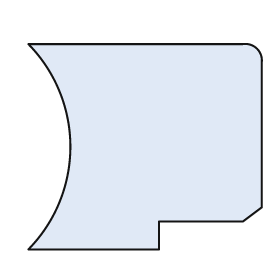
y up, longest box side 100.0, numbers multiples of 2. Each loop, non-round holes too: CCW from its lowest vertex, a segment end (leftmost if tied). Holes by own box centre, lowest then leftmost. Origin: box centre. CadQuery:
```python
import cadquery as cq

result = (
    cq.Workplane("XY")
    .moveTo(-50.0, -44.0)
    .lineTo(6.0, -44.0)
    .lineTo(6.0, -32.0)
    .lineTo(42.0, -32.0)
    .lineTo(50.0, -26.0)
    .lineTo(50.0, 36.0)
    .threePointArc((48.0, 42.0), (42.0, 44.0))
    .lineTo(-50.0, 44.0)
    .threePointArc((-32.0, 0.0), (-50.0, -44.0))
    .close()
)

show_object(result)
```